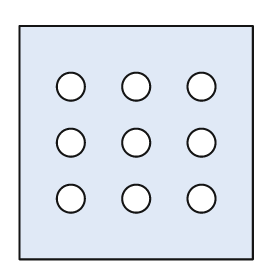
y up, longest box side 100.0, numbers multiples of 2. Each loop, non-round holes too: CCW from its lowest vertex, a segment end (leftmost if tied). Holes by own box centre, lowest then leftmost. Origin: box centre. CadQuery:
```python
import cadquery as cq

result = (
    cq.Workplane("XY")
    .moveTo(-50.0, -50.0)
    .lineTo(50.0, -50.0)
    .lineTo(50.0, 50.0)
    .lineTo(-50.0, 50.0)
    .close()
    .moveTo(-28.0, -24.0)
    .circle(6.0)
    .moveTo(0.0, -24.0)
    .circle(6.0)
    .moveTo(28.0, -24.0)
    .circle(6.0)
    .moveTo(-28.0, 0.0)
    .circle(6.0)
    .moveTo(0.0, 0.0)
    .circle(6.0)
    .moveTo(28.0, 0.0)
    .circle(6.0)
    .moveTo(-28.0, 24.0)
    .circle(6.0)
    .moveTo(0.0, 24.0)
    .circle(6.0)
    .moveTo(28.0, 24.0)
    .circle(6.0)
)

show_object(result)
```